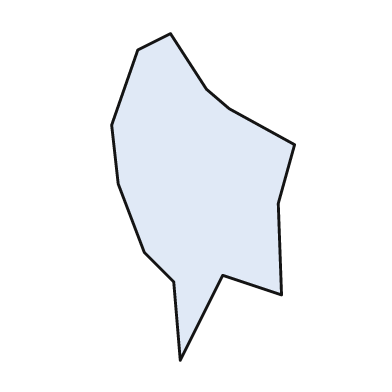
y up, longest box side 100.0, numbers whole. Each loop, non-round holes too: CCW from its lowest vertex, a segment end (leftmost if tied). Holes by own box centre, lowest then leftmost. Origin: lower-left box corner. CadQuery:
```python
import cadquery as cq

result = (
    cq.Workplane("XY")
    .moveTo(21.0, 0.0)
    .lineTo(34.0, 26.0)
    .lineTo(52.0, 20.0)
    .lineTo(51.0, 48.0)
    .lineTo(56.0, 66.0)
    .lineTo(36.0, 77.0)
    .lineTo(29.0, 83.0)
    .lineTo(18.0, 100.0)
    .lineTo(8.0, 95.0)
    .lineTo(0.0, 72.0)
    .lineTo(2.0, 54.0)
    .lineTo(10.0, 33.0)
    .lineTo(19.0, 24.0)
    .close()
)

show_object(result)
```